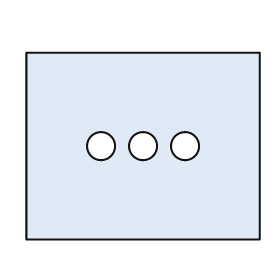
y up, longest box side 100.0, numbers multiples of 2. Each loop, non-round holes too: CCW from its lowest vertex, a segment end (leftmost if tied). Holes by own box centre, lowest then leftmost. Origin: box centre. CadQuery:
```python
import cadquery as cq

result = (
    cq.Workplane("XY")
    .moveTo(-50.0, -40.0)
    .lineTo(50.0, -40.0)
    .lineTo(50.0, 40.0)
    .lineTo(-50.0, 40.0)
    .close()
    .moveTo(-18.0, 0.0)
    .circle(6.0)
    .moveTo(0.0, 0.0)
    .circle(6.0)
    .moveTo(18.0, 0.0)
    .circle(6.0)
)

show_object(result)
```